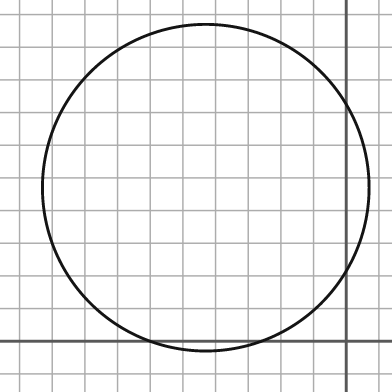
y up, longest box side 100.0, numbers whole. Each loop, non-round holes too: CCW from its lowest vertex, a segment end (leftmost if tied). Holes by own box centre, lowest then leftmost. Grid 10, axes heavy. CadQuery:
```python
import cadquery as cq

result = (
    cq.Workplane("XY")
    .moveTo(-43.0, 47.0)
    .circle(50.0)
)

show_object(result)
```